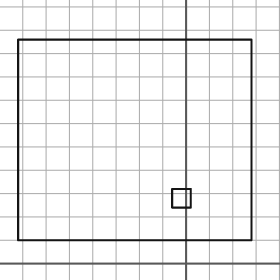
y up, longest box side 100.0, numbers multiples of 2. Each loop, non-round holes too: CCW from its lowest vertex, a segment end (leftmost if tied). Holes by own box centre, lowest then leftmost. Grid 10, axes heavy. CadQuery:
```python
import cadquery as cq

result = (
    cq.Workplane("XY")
    .moveTo(-72.0, 10.0)
    .lineTo(28.0, 10.0)
    .lineTo(28.0, 96.0)
    .lineTo(-72.0, 96.0)
    .close()
    .moveTo(-6.0, 24.0)
    .lineTo(2.0, 24.0)
    .lineTo(2.0, 32.0)
    .lineTo(-6.0, 32.0)
    .close()
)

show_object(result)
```